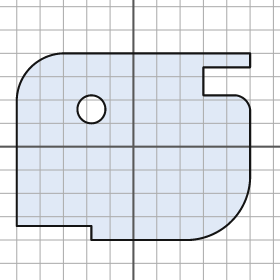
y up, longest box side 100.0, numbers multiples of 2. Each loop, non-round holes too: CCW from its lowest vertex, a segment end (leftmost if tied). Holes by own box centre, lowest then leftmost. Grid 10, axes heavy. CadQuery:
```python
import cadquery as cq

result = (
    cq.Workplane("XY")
    .moveTo(-18.0, -40.0)
    .lineTo(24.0, -40.0)
    .threePointArc((42.0, -32.0), (50.0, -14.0))
    .lineTo(50.0, 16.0)
    .threePointArc((48.0, 20.0), (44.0, 22.0))
    .lineTo(30.0, 22.0)
    .lineTo(30.0, 34.0)
    .lineTo(50.0, 34.0)
    .lineTo(50.0, 40.0)
    .lineTo(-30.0, 40.0)
    .threePointArc((-44.0, 34.0), (-50.0, 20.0))
    .lineTo(-50.0, -34.0)
    .lineTo(-18.0, -34.0)
    .close()
    .moveTo(-18.0, 16.0)
    .circle(6.0)
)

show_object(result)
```